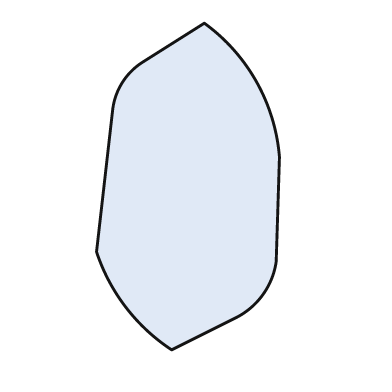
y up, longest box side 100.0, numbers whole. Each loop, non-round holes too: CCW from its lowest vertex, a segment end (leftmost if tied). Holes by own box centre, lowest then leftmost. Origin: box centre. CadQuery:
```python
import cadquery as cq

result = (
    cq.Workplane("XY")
    .moveTo(-5.0, -50.0)
    .lineTo(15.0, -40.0)
    .threePointArc((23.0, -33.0), (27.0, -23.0))
    .lineTo(28.0, 9.0)
    .threePointArc((21.0, 32.0), (5.0, 50.0))
    .lineTo(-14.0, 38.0)
    .threePointArc((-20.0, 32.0), (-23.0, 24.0))
    .lineTo(-28.0, -20.0)
    .threePointArc((-19.0, -37.0), (-5.0, -50.0))
    .close()
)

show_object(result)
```